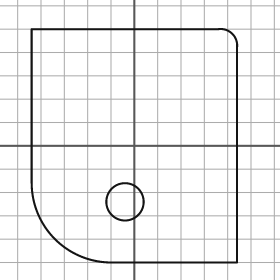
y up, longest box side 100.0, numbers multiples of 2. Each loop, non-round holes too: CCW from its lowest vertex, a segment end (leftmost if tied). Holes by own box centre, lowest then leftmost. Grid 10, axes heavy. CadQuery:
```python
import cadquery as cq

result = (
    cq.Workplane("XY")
    .moveTo(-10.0, -50.0)
    .lineTo(44.0, -50.0)
    .lineTo(44.0, 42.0)
    .threePointArc((42.0, 48.0), (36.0, 50.0))
    .lineTo(-44.0, 50.0)
    .lineTo(-44.0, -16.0)
    .threePointArc((-34.0, -40.0), (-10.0, -50.0))
    .close()
    .moveTo(-4.0, -24.0)
    .circle(8.0)
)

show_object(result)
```